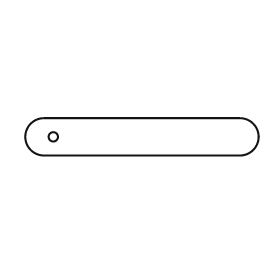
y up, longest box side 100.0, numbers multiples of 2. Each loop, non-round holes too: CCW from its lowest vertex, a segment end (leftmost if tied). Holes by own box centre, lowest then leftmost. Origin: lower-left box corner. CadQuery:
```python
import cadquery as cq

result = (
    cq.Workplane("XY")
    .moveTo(8.0, 0.0)
    .lineTo(92.0, 0.0)
    .threePointArc((100.0, 8.0), (92.0, 16.0))
    .lineTo(8.0, 16.0)
    .threePointArc((0.0, 8.0), (8.0, 0.0))
    .close()
    .moveTo(12.0, 8.0)
    .circle(2.0)
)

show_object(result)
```